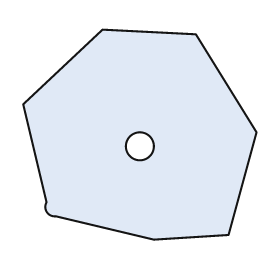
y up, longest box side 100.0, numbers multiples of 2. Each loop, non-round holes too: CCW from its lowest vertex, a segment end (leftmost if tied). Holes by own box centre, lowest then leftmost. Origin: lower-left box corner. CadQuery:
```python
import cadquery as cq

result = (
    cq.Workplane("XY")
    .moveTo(56.0, 0.0)
    .lineTo(88.0, 2.0)
    .lineTo(100.0, 46.0)
    .lineTo(74.0, 88.0)
    .lineTo(34.0, 90.0)
    .lineTo(0.0, 58.0)
    .lineTo(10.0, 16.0)
    .threePointArc((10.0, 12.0), (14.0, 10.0))
    .close()
    .moveTo(50.0, 40.0)
    .circle(6.0)
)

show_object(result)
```